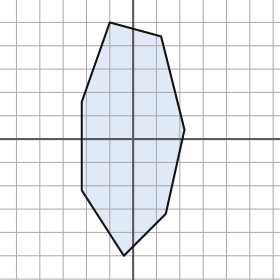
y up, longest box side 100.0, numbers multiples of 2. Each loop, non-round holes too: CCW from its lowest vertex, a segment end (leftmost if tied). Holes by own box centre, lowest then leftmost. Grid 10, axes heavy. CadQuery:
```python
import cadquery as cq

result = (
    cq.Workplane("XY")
    .moveTo(-4.0, -50.0)
    .lineTo(14.0, -32.0)
    .lineTo(22.0, 4.0)
    .lineTo(12.0, 44.0)
    .lineTo(-10.0, 50.0)
    .lineTo(-22.0, 16.0)
    .lineTo(-22.0, -22.0)
    .close()
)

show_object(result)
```